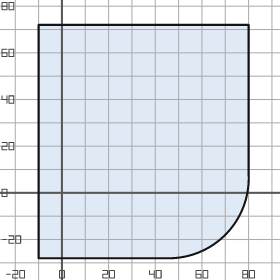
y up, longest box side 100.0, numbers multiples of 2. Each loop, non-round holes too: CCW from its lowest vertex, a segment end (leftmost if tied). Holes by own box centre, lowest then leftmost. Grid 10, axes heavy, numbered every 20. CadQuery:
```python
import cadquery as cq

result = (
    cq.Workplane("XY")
    .moveTo(-10.0, -28.0)
    .lineTo(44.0, -28.0)
    .threePointArc((70.0, -18.0), (80.0, 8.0))
    .lineTo(80.0, 72.0)
    .lineTo(-10.0, 72.0)
    .close()
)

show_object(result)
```